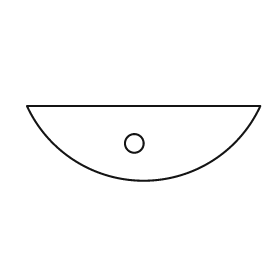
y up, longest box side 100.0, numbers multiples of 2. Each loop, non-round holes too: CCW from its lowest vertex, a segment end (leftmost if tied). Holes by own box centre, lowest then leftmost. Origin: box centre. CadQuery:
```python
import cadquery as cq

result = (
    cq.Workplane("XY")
    .moveTo(-50.0, 16.0)
    .threePointArc((0.0, -16.0), (50.0, 16.0))
    .close()
    .moveTo(-4.0, 0.0)
    .circle(4.0)
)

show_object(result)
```